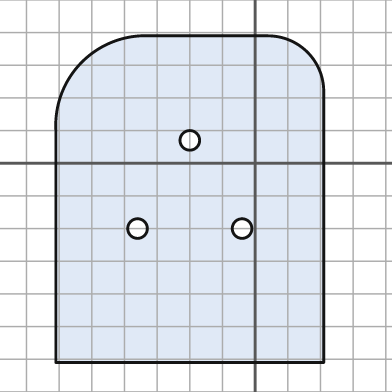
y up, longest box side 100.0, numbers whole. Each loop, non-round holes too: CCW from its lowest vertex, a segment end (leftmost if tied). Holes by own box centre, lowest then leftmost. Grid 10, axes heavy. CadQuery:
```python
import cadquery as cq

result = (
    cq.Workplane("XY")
    .moveTo(-61.0, -61.0)
    .lineTo(21.0, -61.0)
    .lineTo(21.0, 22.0)
    .threePointArc((16.0, 34.0), (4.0, 39.0))
    .lineTo(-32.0, 39.0)
    .threePointArc((-53.0, 31.0), (-61.0, 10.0))
    .close()
    .moveTo(-36.0, -20.0)
    .circle(3.0)
    .moveTo(-4.0, -20.0)
    .circle(3.0)
    .moveTo(-20.0, 7.0)
    .circle(3.0)
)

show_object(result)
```